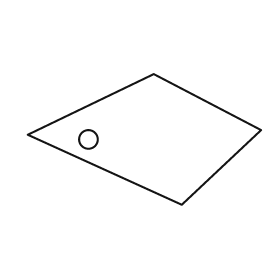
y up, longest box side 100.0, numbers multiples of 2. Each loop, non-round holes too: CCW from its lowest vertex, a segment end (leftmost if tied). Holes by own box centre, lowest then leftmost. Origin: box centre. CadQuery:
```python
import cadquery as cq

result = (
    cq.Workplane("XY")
    .moveTo(16.0, -28.0)
    .lineTo(50.0, 4.0)
    .lineTo(4.0, 28.0)
    .lineTo(-50.0, 2.0)
    .close()
    .moveTo(-24.0, 0.0)
    .circle(4.0)
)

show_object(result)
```